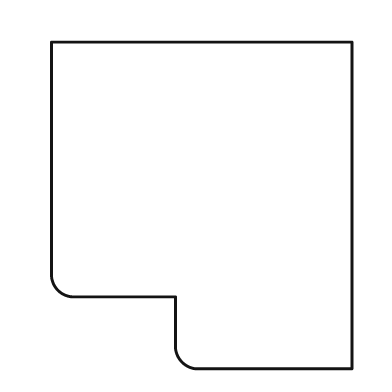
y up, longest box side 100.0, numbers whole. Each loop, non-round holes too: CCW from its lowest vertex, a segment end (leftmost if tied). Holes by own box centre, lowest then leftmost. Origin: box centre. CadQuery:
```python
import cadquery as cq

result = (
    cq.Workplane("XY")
    .moveTo(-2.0, -50.0)
    .lineTo(46.0, -50.0)
    .lineTo(46.0, 50.0)
    .lineTo(-46.0, 50.0)
    .lineTo(-46.0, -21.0)
    .threePointArc((-44.0, -26.0), (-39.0, -28.0))
    .lineTo(-8.0, -28.0)
    .lineTo(-8.0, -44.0)
    .threePointArc((-6.0, -48.0), (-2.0, -50.0))
    .close()
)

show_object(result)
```